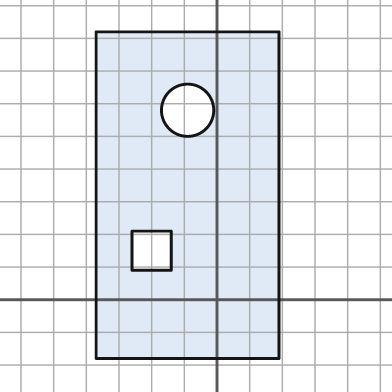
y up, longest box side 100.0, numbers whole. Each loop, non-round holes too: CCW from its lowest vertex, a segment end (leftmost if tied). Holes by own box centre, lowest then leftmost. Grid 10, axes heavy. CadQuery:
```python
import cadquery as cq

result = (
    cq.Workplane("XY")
    .moveTo(-37.0, -18.0)
    .lineTo(19.0, -18.0)
    .lineTo(19.0, 82.0)
    .lineTo(-37.0, 82.0)
    .close()
    .moveTo(-26.0, 9.0)
    .lineTo(-14.0, 9.0)
    .lineTo(-14.0, 21.0)
    .lineTo(-26.0, 21.0)
    .close()
    .moveTo(-9.0, 58.0)
    .circle(8.0)
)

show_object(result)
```